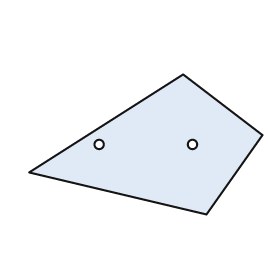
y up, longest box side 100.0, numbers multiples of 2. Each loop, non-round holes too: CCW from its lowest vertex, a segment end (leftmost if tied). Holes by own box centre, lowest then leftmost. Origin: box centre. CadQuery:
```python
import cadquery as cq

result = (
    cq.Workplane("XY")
    .moveTo(26.0, -30.0)
    .lineTo(50.0, 4.0)
    .lineTo(16.0, 30.0)
    .lineTo(-50.0, -12.0)
    .close()
    .moveTo(-20.0, 0.0)
    .circle(2.0)
    .moveTo(20.0, 0.0)
    .circle(2.0)
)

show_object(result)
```